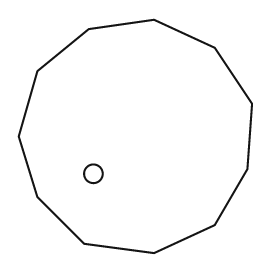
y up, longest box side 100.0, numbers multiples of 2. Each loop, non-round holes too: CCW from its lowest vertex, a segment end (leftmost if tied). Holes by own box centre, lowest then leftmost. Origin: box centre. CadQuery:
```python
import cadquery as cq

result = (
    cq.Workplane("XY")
    .moveTo(8.0, -50.0)
    .lineTo(34.0, -38.0)
    .lineTo(48.0, -14.0)
    .lineTo(50.0, 14.0)
    .lineTo(34.0, 38.0)
    .lineTo(8.0, 50.0)
    .lineTo(-20.0, 46.0)
    .lineTo(-42.0, 28.0)
    .lineTo(-50.0, 0.0)
    .lineTo(-42.0, -26.0)
    .lineTo(-22.0, -46.0)
    .close()
    .moveTo(-18.0, -16.0)
    .circle(4.0)
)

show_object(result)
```